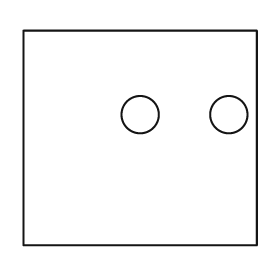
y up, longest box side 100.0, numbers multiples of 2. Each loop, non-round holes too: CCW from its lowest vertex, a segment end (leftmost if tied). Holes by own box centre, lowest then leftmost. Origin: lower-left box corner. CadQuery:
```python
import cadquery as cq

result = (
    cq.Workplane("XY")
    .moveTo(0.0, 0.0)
    .lineTo(100.0, 0.0)
    .lineTo(100.0, 92.0)
    .lineTo(0.0, 92.0)
    .close()
    .moveTo(50.0, 56.0)
    .circle(8.0)
    .moveTo(88.0, 56.0)
    .circle(8.0)
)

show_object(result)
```